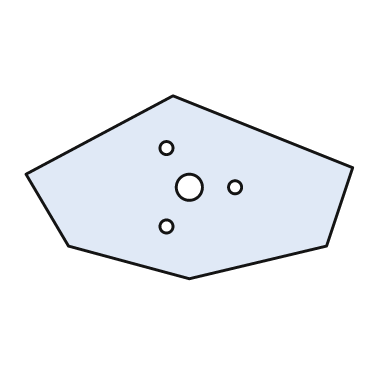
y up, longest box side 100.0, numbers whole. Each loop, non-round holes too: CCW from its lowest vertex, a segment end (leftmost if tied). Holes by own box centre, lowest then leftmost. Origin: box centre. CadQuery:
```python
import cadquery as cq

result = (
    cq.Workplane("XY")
    .moveTo(0.0, -28.0)
    .lineTo(42.0, -18.0)
    .lineTo(50.0, 6.0)
    .lineTo(-5.0, 28.0)
    .lineTo(-50.0, 4.0)
    .lineTo(-37.0, -18.0)
    .close()
    .moveTo(-7.0, -12.0)
    .circle(2.0)
    .moveTo(0.0, 0.0)
    .circle(4.0)
    .moveTo(14.0, 0.0)
    .circle(2.0)
    .moveTo(-7.0, 12.0)
    .circle(2.0)
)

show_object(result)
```